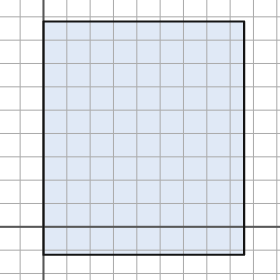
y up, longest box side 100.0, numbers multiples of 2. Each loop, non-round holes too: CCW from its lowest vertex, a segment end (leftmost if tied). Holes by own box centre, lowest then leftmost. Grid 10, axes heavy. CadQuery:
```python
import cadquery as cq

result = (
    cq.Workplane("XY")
    .moveTo(0.0, -12.0)
    .lineTo(86.0, -12.0)
    .lineTo(86.0, 88.0)
    .lineTo(0.0, 88.0)
    .close()
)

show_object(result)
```